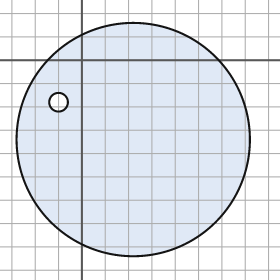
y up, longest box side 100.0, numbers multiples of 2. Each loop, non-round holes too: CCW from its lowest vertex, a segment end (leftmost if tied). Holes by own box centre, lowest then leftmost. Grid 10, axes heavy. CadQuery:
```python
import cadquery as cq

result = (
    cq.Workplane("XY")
    .moveTo(22.0, -34.0)
    .circle(50.0)
    .moveTo(-10.0, -18.0)
    .circle(4.0)
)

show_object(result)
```